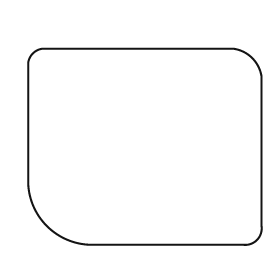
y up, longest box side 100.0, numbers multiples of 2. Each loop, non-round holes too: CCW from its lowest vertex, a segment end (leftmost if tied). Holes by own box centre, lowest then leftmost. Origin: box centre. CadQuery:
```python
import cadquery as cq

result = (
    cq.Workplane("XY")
    .moveTo(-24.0, -42.0)
    .lineTo(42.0, -42.0)
    .threePointArc((48.0, -40.0), (50.0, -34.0))
    .lineTo(50.0, 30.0)
    .threePointArc((46.0, 38.0), (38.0, 42.0))
    .lineTo(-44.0, 42.0)
    .threePointArc((-48.0, 40.0), (-50.0, 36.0))
    .lineTo(-50.0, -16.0)
    .threePointArc((-42.0, -34.0), (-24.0, -42.0))
    .close()
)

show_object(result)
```